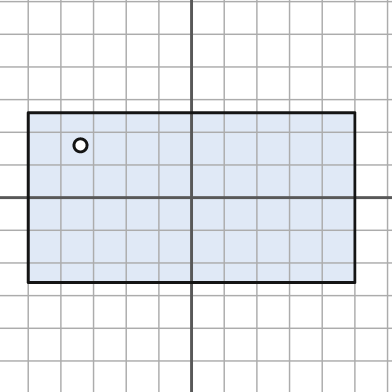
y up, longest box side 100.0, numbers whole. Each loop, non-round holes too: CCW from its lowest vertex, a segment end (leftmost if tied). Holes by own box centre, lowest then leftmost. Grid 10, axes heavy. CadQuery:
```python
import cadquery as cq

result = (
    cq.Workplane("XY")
    .moveTo(-50.0, -26.0)
    .lineTo(50.0, -26.0)
    .lineTo(50.0, 26.0)
    .lineTo(-50.0, 26.0)
    .close()
    .moveTo(-34.0, 16.0)
    .circle(2.0)
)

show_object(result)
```